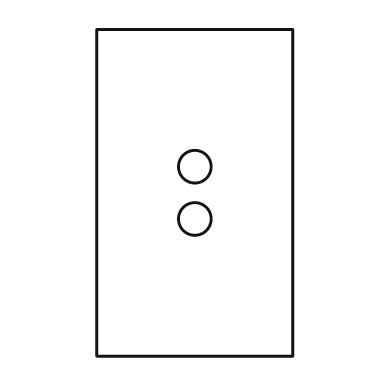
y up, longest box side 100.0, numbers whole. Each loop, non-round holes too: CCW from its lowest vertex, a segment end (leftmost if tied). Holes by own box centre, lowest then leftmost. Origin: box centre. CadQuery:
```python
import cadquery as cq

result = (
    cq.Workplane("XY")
    .moveTo(-30.0, -50.0)
    .lineTo(30.0, -50.0)
    .lineTo(30.0, 50.0)
    .lineTo(-30.0, 50.0)
    .close()
    .moveTo(0.0, -8.0)
    .circle(5.0)
    .moveTo(0.0, 8.0)
    .circle(5.0)
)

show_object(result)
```